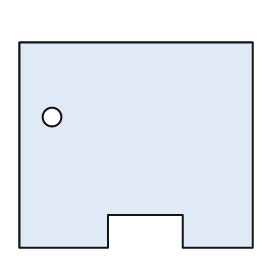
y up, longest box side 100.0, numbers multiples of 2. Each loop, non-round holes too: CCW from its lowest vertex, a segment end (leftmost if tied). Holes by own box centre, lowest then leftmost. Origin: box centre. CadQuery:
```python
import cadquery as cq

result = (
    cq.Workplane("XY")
    .moveTo(-50.0, -44.0)
    .lineTo(-12.0, -44.0)
    .lineTo(-12.0, -30.0)
    .lineTo(20.0, -30.0)
    .lineTo(20.0, -44.0)
    .lineTo(50.0, -44.0)
    .lineTo(50.0, 44.0)
    .lineTo(-50.0, 44.0)
    .close()
    .moveTo(-36.0, 12.0)
    .circle(4.0)
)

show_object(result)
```